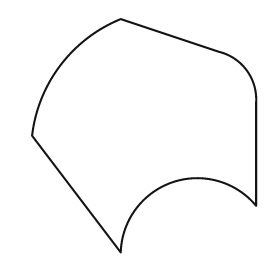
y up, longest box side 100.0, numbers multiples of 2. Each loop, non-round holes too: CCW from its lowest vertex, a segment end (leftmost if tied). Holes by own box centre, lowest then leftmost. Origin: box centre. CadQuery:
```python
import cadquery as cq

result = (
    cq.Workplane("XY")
    .moveTo(-10.0, -50.0)
    .threePointArc((12.0, -20.0), (48.0, -30.0))
    .lineTo(48.0, 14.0)
    .threePointArc((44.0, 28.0), (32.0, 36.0))
    .lineTo(-10.0, 50.0)
    .threePointArc((-36.0, 30.0), (-48.0, 0.0))
    .close()
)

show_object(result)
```